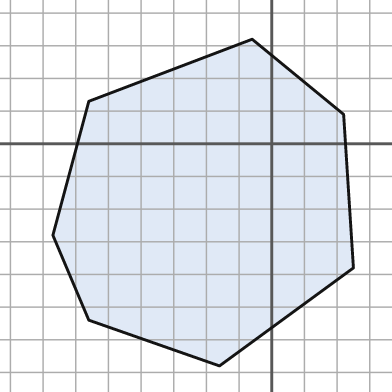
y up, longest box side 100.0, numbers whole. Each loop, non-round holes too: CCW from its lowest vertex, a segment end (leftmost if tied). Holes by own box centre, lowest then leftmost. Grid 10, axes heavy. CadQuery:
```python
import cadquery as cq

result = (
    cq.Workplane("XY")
    .moveTo(-16.0, -68.0)
    .lineTo(25.0, -38.0)
    .lineTo(22.0, 9.0)
    .lineTo(-6.0, 32.0)
    .lineTo(-56.0, 13.0)
    .lineTo(-67.0, -28.0)
    .lineTo(-56.0, -54.0)
    .close()
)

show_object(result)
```